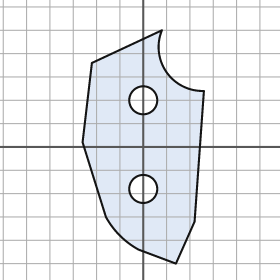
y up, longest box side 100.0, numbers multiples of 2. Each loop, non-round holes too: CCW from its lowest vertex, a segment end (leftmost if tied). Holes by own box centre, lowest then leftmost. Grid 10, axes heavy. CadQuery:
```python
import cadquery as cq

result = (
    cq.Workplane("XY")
    .moveTo(14.0, -50.0)
    .lineTo(22.0, -32.0)
    .lineTo(26.0, 24.0)
    .threePointArc((10.0, 32.0), (8.0, 50.0))
    .lineTo(-22.0, 36.0)
    .lineTo(-26.0, 2.0)
    .lineTo(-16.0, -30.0)
    .threePointArc((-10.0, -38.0), (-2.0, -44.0))
    .close()
    .moveTo(0.0, -18.0)
    .circle(6.0)
    .moveTo(0.0, 20.0)
    .circle(6.0)
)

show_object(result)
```